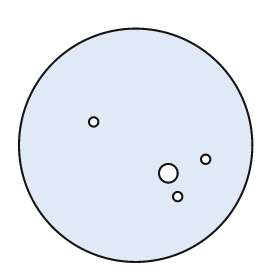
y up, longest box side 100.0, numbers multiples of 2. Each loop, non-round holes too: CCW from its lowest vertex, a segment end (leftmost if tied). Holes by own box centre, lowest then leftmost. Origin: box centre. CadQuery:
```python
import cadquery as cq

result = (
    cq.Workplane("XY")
    .moveTo(0.0, 0.0)
    .circle(50.0)
    .moveTo(18.0, -22.0)
    .circle(2.0)
    .moveTo(14.0, -12.0)
    .circle(4.0)
    .moveTo(30.0, -6.0)
    .circle(2.0)
    .moveTo(-18.0, 10.0)
    .circle(2.0)
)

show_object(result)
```